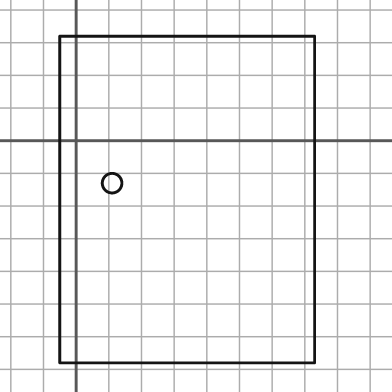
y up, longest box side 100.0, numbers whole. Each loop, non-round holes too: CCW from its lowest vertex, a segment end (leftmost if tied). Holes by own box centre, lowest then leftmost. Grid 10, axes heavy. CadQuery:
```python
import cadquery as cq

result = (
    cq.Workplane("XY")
    .moveTo(-5.0, -68.0)
    .lineTo(73.0, -68.0)
    .lineTo(73.0, 32.0)
    .lineTo(-5.0, 32.0)
    .close()
    .moveTo(11.0, -13.0)
    .circle(3.0)
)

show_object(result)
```